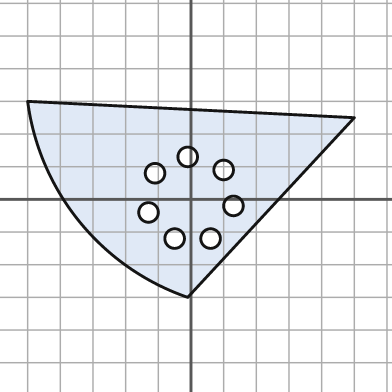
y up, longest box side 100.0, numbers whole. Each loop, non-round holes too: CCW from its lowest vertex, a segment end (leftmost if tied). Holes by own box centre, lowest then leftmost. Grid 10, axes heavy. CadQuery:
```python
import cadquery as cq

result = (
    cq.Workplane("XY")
    .moveTo(-1.0, -30.0)
    .lineTo(50.0, 25.0)
    .lineTo(-50.0, 30.0)
    .threePointArc((-34.0, -7.0), (-1.0, -30.0))
    .close()
    .moveTo(-5.0, -12.0)
    .circle(3.0)
    .moveTo(6.0, -12.0)
    .circle(3.0)
    .moveTo(-13.0, -4.0)
    .circle(3.0)
    .moveTo(13.0, -2.0)
    .circle(3.0)
    .moveTo(-11.0, 8.0)
    .circle(3.0)
    .moveTo(10.0, 9.0)
    .circle(3.0)
    .moveTo(-1.0, 13.0)
    .circle(3.0)
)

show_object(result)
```